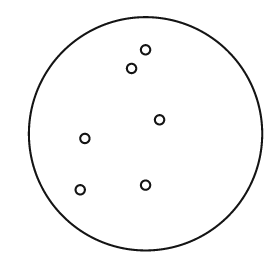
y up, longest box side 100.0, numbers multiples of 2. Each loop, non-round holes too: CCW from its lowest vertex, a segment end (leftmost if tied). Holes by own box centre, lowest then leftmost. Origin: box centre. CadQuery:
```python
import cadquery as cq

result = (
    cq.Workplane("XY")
    .moveTo(0.0, 0.0)
    .circle(50.0)
    .moveTo(-28.0, -24.0)
    .circle(2.0)
    .moveTo(0.0, -22.0)
    .circle(2.0)
    .moveTo(-26.0, -2.0)
    .circle(2.0)
    .moveTo(6.0, 6.0)
    .circle(2.0)
    .moveTo(-6.0, 28.0)
    .circle(2.0)
    .moveTo(0.0, 36.0)
    .circle(2.0)
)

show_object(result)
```